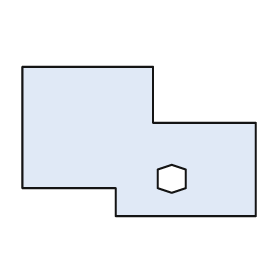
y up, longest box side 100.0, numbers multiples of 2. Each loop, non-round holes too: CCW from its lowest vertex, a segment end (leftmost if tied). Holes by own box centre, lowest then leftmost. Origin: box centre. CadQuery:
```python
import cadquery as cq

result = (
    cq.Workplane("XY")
    .moveTo(-10.0, -32.0)
    .lineTo(50.0, -32.0)
    .lineTo(50.0, 8.0)
    .lineTo(6.0, 8.0)
    .lineTo(6.0, 32.0)
    .lineTo(-50.0, 32.0)
    .lineTo(-50.0, -20.0)
    .lineTo(-10.0, -20.0)
    .close()
    .moveTo(14.0, -22.0)
    .lineTo(20.0, -20.0)
    .lineTo(20.0, -12.0)
    .lineTo(14.0, -10.0)
    .lineTo(8.0, -12.0)
    .lineTo(8.0, -20.0)
    .close()
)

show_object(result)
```